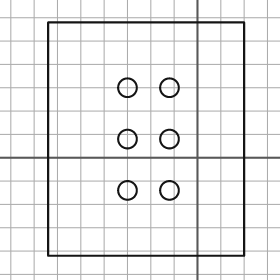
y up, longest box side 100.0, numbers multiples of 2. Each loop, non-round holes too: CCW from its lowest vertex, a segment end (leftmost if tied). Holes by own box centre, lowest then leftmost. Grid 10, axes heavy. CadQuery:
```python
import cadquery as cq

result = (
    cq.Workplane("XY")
    .moveTo(-64.0, -42.0)
    .lineTo(20.0, -42.0)
    .lineTo(20.0, 58.0)
    .lineTo(-64.0, 58.0)
    .close()
    .moveTo(-30.0, -14.0)
    .circle(4.0)
    .moveTo(-12.0, -14.0)
    .circle(4.0)
    .moveTo(-30.0, 8.0)
    .circle(4.0)
    .moveTo(-12.0, 8.0)
    .circle(4.0)
    .moveTo(-30.0, 30.0)
    .circle(4.0)
    .moveTo(-12.0, 30.0)
    .circle(4.0)
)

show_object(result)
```